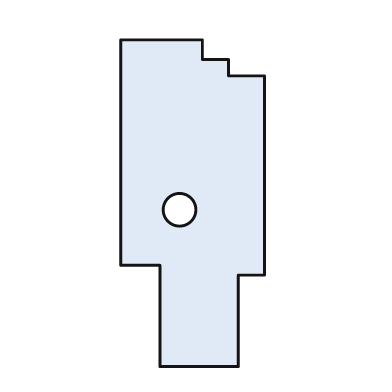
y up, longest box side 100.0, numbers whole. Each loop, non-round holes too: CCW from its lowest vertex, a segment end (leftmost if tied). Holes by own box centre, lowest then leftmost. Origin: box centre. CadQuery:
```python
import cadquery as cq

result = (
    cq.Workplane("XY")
    .moveTo(-10.0, -50.0)
    .lineTo(14.0, -50.0)
    .lineTo(14.0, -22.0)
    .lineTo(22.0, -22.0)
    .lineTo(22.0, 39.0)
    .lineTo(11.0, 39.0)
    .lineTo(11.0, 44.0)
    .lineTo(3.0, 44.0)
    .lineTo(3.0, 50.0)
    .lineTo(-22.0, 50.0)
    .lineTo(-22.0, -19.0)
    .lineTo(-10.0, -19.0)
    .close()
    .moveTo(-4.0, -2.0)
    .circle(5.0)
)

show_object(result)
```